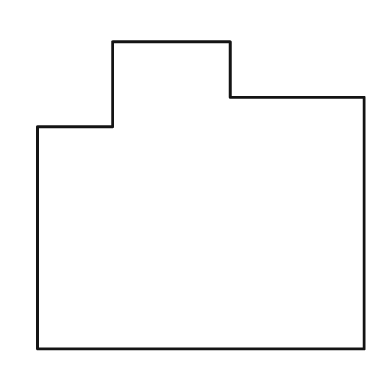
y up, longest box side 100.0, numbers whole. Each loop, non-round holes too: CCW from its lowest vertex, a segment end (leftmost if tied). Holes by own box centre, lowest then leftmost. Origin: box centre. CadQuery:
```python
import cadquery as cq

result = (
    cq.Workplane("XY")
    .moveTo(-50.0, -47.0)
    .lineTo(50.0, -47.0)
    .lineTo(50.0, 30.0)
    .lineTo(9.0, 30.0)
    .lineTo(9.0, 47.0)
    .lineTo(-27.0, 47.0)
    .lineTo(-27.0, 21.0)
    .lineTo(-50.0, 21.0)
    .close()
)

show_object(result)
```